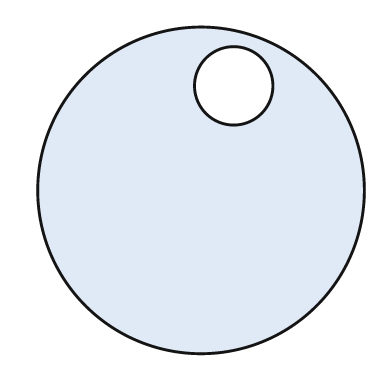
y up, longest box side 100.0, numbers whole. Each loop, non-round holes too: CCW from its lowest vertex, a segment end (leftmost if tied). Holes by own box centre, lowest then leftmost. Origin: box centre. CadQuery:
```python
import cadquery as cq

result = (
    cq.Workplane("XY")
    .moveTo(0.0, 0.0)
    .circle(50.0)
    .moveTo(10.0, 32.0)
    .circle(12.0)
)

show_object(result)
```